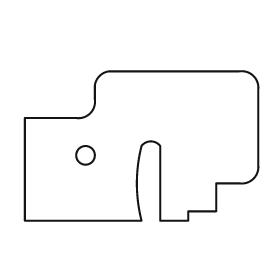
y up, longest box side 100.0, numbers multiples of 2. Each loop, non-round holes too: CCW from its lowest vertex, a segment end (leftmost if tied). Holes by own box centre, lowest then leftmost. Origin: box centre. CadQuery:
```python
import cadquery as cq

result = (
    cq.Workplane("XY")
    .moveTo(-50.0, -32.0)
    .lineTo(0.0, -32.0)
    .threePointArc((-2.0, -16.0), (0.0, 0.0))
    .threePointArc((4.0, 2.0), (8.0, 0.0))
    .lineTo(8.0, -32.0)
    .lineTo(20.0, -32.0)
    .lineTo(20.0, -28.0)
    .lineTo(32.0, -28.0)
    .lineTo(32.0, -16.0)
    .lineTo(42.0, -16.0)
    .threePointArc((48.0, -14.0), (50.0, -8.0))
    .lineTo(50.0, 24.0)
    .threePointArc((48.0, 30.0), (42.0, 32.0))
    .lineTo(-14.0, 32.0)
    .threePointArc((-18.0, 30.0), (-20.0, 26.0))
    .lineTo(-20.0, 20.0)
    .threePointArc((-22.0, 14.0), (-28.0, 12.0))
    .lineTo(-50.0, 12.0)
    .close()
    .moveTo(-24.0, -4.0)
    .circle(4.0)
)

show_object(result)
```